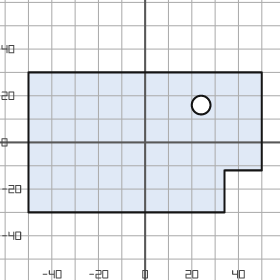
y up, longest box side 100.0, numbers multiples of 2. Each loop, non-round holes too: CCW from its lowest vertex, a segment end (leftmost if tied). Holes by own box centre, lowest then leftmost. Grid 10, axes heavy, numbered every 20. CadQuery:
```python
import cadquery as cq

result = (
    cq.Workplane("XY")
    .moveTo(-50.0, -30.0)
    .lineTo(34.0, -30.0)
    .lineTo(34.0, -12.0)
    .lineTo(50.0, -12.0)
    .lineTo(50.0, 30.0)
    .lineTo(-50.0, 30.0)
    .close()
    .moveTo(24.0, 16.0)
    .circle(4.0)
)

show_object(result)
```